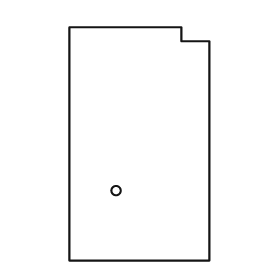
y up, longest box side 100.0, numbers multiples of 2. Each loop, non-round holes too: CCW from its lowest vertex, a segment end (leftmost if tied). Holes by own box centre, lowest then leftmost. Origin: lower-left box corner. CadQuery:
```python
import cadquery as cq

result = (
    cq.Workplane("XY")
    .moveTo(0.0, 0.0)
    .lineTo(60.0, 0.0)
    .lineTo(60.0, 94.0)
    .lineTo(48.0, 94.0)
    .lineTo(48.0, 100.0)
    .lineTo(0.0, 100.0)
    .close()
    .moveTo(20.0, 30.0)
    .circle(2.0)
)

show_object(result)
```